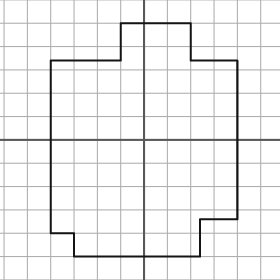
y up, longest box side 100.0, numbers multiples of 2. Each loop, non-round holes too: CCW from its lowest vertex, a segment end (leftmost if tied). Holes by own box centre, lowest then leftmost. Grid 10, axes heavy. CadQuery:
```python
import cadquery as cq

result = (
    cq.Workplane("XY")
    .moveTo(-30.0, -50.0)
    .lineTo(24.0, -50.0)
    .lineTo(24.0, -34.0)
    .lineTo(40.0, -34.0)
    .lineTo(40.0, 34.0)
    .lineTo(20.0, 34.0)
    .lineTo(20.0, 50.0)
    .lineTo(-10.0, 50.0)
    .lineTo(-10.0, 34.0)
    .lineTo(-40.0, 34.0)
    .lineTo(-40.0, -40.0)
    .lineTo(-30.0, -40.0)
    .close()
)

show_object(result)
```